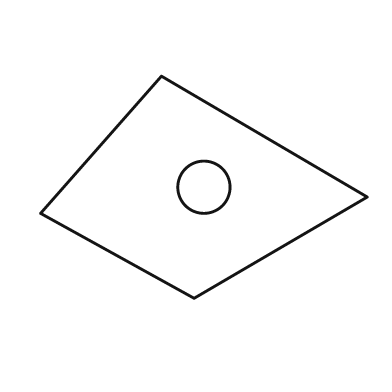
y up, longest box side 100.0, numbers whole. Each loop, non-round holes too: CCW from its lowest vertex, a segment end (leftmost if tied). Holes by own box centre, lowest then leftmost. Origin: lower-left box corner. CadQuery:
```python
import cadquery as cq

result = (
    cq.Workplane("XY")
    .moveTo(47.0, 0.0)
    .lineTo(100.0, 31.0)
    .lineTo(37.0, 68.0)
    .lineTo(0.0, 26.0)
    .close()
    .moveTo(50.0, 34.0)
    .circle(8.0)
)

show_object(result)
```